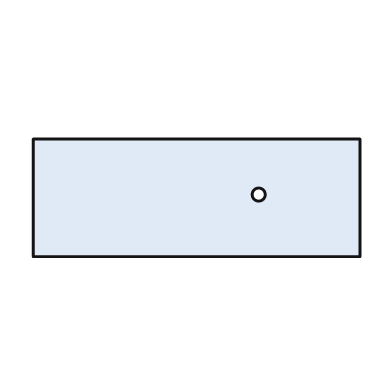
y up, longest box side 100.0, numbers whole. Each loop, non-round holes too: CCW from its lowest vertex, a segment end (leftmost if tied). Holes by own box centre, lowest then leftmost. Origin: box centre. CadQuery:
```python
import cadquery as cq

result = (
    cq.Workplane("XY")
    .moveTo(-50.0, -18.0)
    .lineTo(50.0, -18.0)
    .lineTo(50.0, 18.0)
    .lineTo(-50.0, 18.0)
    .close()
    .moveTo(19.0, 1.0)
    .circle(2.0)
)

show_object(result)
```